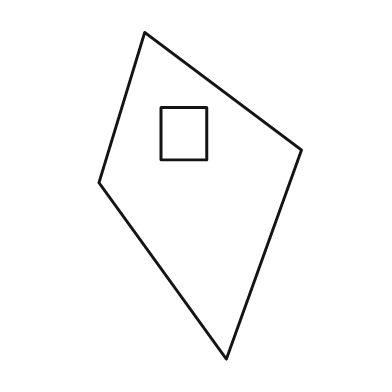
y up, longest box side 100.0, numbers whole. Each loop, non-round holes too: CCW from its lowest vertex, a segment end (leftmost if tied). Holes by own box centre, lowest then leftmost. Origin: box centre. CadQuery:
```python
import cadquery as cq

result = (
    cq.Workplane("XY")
    .moveTo(8.0, -50.0)
    .lineTo(31.0, 14.0)
    .lineTo(-17.0, 50.0)
    .lineTo(-31.0, 4.0)
    .close()
    .moveTo(-12.0, 11.0)
    .lineTo(2.0, 11.0)
    .lineTo(2.0, 27.0)
    .lineTo(-12.0, 27.0)
    .close()
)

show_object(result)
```